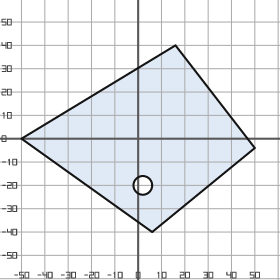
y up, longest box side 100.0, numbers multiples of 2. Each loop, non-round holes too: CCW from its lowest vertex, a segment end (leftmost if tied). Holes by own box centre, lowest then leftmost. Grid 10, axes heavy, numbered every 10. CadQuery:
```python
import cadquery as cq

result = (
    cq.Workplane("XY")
    .moveTo(6.0, -40.0)
    .lineTo(50.0, -4.0)
    .lineTo(16.0, 40.0)
    .lineTo(-50.0, 0.0)
    .close()
    .moveTo(2.0, -20.0)
    .circle(4.0)
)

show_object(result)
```